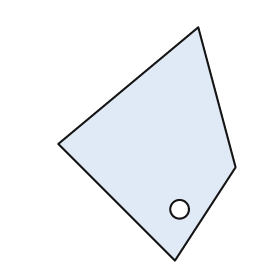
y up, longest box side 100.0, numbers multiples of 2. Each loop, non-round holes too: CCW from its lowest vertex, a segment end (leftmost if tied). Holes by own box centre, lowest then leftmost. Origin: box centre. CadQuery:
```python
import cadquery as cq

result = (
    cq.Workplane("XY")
    .moveTo(12.0, -50.0)
    .lineTo(38.0, -10.0)
    .lineTo(22.0, 50.0)
    .lineTo(-38.0, 0.0)
    .close()
    .moveTo(14.0, -28.0)
    .circle(4.0)
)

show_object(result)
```